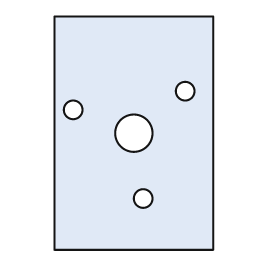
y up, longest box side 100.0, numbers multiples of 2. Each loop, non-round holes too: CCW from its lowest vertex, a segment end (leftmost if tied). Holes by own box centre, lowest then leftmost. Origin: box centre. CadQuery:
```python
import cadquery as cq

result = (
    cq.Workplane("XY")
    .moveTo(-34.0, -50.0)
    .lineTo(34.0, -50.0)
    .lineTo(34.0, 50.0)
    .lineTo(-34.0, 50.0)
    .close()
    .moveTo(4.0, -28.0)
    .circle(4.0)
    .moveTo(0.0, 0.0)
    .circle(8.0)
    .moveTo(-26.0, 10.0)
    .circle(4.0)
    .moveTo(22.0, 18.0)
    .circle(4.0)
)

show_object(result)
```